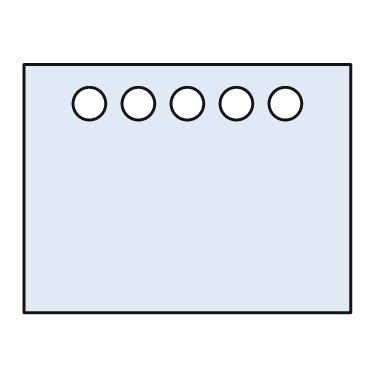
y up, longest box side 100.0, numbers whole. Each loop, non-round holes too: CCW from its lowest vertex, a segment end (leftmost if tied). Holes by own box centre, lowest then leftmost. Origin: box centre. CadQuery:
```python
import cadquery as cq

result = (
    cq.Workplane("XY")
    .moveTo(-50.0, -38.0)
    .lineTo(50.0, -38.0)
    .lineTo(50.0, 38.0)
    .lineTo(-50.0, 38.0)
    .close()
    .moveTo(-30.0, 26.0)
    .circle(5.0)
    .moveTo(-15.0, 26.0)
    .circle(5.0)
    .moveTo(0.0, 26.0)
    .circle(5.0)
    .moveTo(15.0, 26.0)
    .circle(5.0)
    .moveTo(30.0, 26.0)
    .circle(5.0)
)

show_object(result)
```